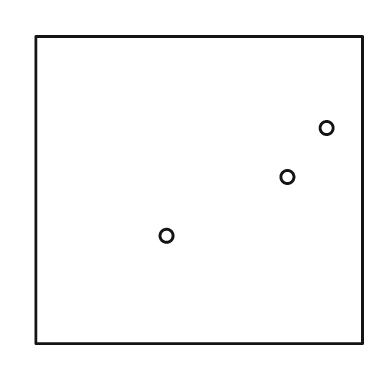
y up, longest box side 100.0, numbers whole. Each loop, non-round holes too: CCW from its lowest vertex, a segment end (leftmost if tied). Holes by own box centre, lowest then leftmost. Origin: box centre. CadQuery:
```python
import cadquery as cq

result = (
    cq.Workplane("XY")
    .moveTo(-50.0, -47.0)
    .lineTo(50.0, -47.0)
    .lineTo(50.0, 47.0)
    .lineTo(-50.0, 47.0)
    .close()
    .moveTo(-10.0, -14.0)
    .circle(2.0)
    .moveTo(27.0, 4.0)
    .circle(2.0)
    .moveTo(39.0, 19.0)
    .circle(2.0)
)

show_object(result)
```